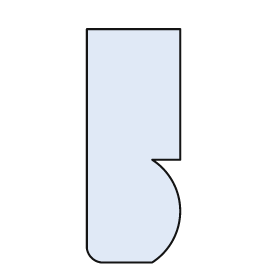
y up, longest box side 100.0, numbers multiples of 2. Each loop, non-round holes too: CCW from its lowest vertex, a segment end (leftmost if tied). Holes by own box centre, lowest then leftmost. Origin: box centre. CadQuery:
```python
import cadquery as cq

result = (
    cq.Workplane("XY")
    .moveTo(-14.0, -50.0)
    .lineTo(8.0, -50.0)
    .threePointArc((20.0, -28.0), (8.0, -6.0))
    .lineTo(20.0, -6.0)
    .lineTo(20.0, 50.0)
    .lineTo(-20.0, 50.0)
    .lineTo(-20.0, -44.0)
    .threePointArc((-18.0, -48.0), (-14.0, -50.0))
    .close()
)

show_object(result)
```